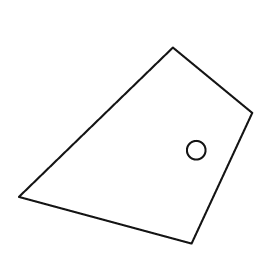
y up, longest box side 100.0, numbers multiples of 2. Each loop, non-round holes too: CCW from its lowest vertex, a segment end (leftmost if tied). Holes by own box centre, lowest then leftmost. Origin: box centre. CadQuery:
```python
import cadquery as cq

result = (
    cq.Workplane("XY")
    .moveTo(24.0, -42.0)
    .lineTo(50.0, 14.0)
    .lineTo(16.0, 42.0)
    .lineTo(-50.0, -22.0)
    .close()
    .moveTo(26.0, -2.0)
    .circle(4.0)
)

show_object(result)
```